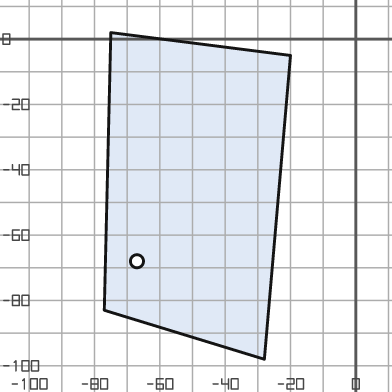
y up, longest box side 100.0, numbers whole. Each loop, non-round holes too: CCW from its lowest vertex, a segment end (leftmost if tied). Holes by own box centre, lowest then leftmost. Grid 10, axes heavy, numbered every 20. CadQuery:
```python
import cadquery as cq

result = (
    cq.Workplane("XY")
    .moveTo(-28.0, -98.0)
    .lineTo(-20.0, -5.0)
    .lineTo(-75.0, 2.0)
    .lineTo(-77.0, -83.0)
    .close()
    .moveTo(-67.0, -68.0)
    .circle(2.0)
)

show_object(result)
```